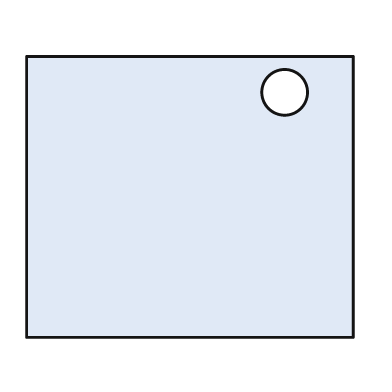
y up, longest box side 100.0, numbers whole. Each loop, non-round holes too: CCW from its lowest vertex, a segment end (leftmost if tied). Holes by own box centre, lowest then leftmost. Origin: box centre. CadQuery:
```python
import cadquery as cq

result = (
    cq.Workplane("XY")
    .moveTo(-50.0, -43.0)
    .lineTo(50.0, -43.0)
    .lineTo(50.0, 43.0)
    .lineTo(-50.0, 43.0)
    .close()
    .moveTo(29.0, 32.0)
    .circle(7.0)
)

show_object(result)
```